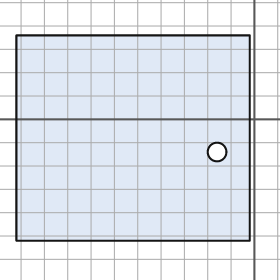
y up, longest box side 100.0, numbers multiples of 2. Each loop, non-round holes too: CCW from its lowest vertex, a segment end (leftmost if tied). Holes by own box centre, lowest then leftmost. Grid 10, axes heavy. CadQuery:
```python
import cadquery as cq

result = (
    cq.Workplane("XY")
    .moveTo(-102.0, -52.0)
    .lineTo(-2.0, -52.0)
    .lineTo(-2.0, 36.0)
    .lineTo(-102.0, 36.0)
    .close()
    .moveTo(-16.0, -14.0)
    .circle(4.0)
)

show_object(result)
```